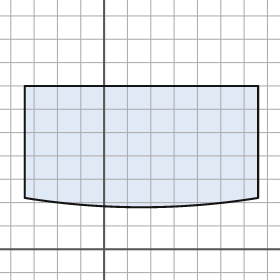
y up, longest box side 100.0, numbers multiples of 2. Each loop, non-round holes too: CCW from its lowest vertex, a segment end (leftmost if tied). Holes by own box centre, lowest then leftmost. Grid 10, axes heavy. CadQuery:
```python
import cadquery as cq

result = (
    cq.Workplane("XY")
    .moveTo(-34.0, 22.0)
    .threePointArc((16.0, 18.0), (66.0, 22.0))
    .lineTo(66.0, 70.0)
    .lineTo(-34.0, 70.0)
    .close()
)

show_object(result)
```